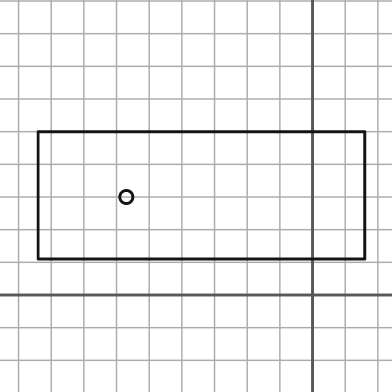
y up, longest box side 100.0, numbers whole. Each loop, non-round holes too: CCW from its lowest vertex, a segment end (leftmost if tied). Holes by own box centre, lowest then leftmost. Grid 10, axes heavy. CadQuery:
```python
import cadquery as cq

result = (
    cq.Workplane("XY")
    .moveTo(-84.0, 11.0)
    .lineTo(16.0, 11.0)
    .lineTo(16.0, 50.0)
    .lineTo(-84.0, 50.0)
    .close()
    .moveTo(-57.0, 30.0)
    .circle(2.0)
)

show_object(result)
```